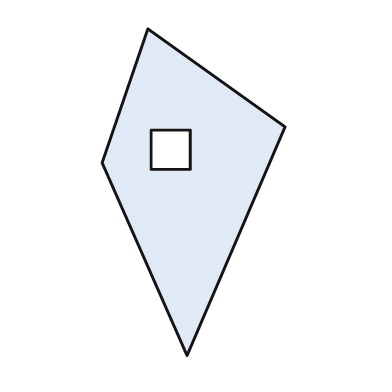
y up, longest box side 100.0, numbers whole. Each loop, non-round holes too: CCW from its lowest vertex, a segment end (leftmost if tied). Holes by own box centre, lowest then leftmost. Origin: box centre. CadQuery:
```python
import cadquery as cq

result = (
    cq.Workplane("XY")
    .moveTo(-2.0, -50.0)
    .lineTo(28.0, 20.0)
    .lineTo(-14.0, 50.0)
    .lineTo(-28.0, 9.0)
    .close()
    .moveTo(-13.0, 7.0)
    .lineTo(-1.0, 7.0)
    .lineTo(-1.0, 19.0)
    .lineTo(-13.0, 19.0)
    .close()
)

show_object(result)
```